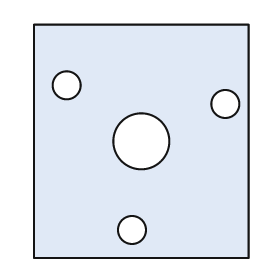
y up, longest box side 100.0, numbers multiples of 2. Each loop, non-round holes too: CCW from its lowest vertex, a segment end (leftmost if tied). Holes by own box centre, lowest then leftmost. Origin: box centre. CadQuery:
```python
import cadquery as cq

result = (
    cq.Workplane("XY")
    .moveTo(-46.0, -50.0)
    .lineTo(46.0, -50.0)
    .lineTo(46.0, 50.0)
    .lineTo(-46.0, 50.0)
    .close()
    .moveTo(-4.0, -38.0)
    .circle(6.0)
    .moveTo(0.0, 0.0)
    .circle(12.0)
    .moveTo(36.0, 16.0)
    .circle(6.0)
    .moveTo(-32.0, 24.0)
    .circle(6.0)
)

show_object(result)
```